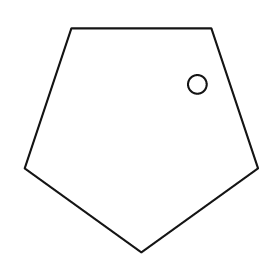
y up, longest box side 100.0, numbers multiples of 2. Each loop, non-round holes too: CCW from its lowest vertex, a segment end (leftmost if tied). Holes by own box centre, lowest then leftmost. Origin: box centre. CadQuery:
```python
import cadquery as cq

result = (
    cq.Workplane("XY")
    .moveTo(0.0, -48.0)
    .lineTo(50.0, -12.0)
    .lineTo(30.0, 48.0)
    .lineTo(-30.0, 48.0)
    .lineTo(-50.0, -12.0)
    .close()
    .moveTo(24.0, 24.0)
    .circle(4.0)
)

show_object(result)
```